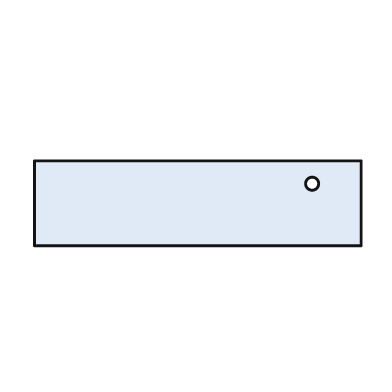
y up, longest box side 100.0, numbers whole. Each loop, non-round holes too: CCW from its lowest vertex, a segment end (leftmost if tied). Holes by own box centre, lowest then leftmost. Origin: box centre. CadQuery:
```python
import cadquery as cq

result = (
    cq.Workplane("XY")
    .moveTo(-50.0, -13.0)
    .lineTo(50.0, -13.0)
    .lineTo(50.0, 13.0)
    .lineTo(-50.0, 13.0)
    .close()
    .moveTo(35.0, 6.0)
    .circle(2.0)
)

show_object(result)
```